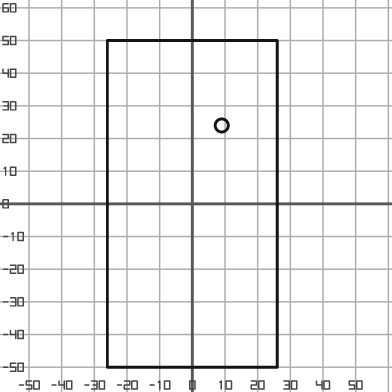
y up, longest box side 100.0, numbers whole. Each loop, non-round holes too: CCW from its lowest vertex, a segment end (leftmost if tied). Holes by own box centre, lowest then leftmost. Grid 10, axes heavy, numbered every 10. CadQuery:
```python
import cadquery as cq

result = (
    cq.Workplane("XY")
    .moveTo(-26.0, -50.0)
    .lineTo(26.0, -50.0)
    .lineTo(26.0, 50.0)
    .lineTo(-26.0, 50.0)
    .close()
    .moveTo(9.0, 24.0)
    .circle(2.0)
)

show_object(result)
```